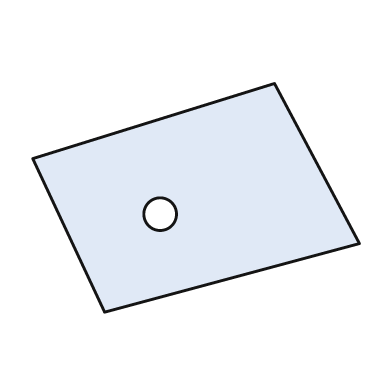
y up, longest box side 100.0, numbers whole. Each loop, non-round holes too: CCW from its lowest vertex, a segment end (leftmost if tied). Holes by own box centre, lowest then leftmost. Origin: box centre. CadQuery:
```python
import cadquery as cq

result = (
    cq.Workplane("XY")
    .moveTo(-28.0, -35.0)
    .lineTo(50.0, -14.0)
    .lineTo(24.0, 35.0)
    .lineTo(-50.0, 12.0)
    .close()
    .moveTo(-11.0, -5.0)
    .circle(5.0)
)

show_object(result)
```